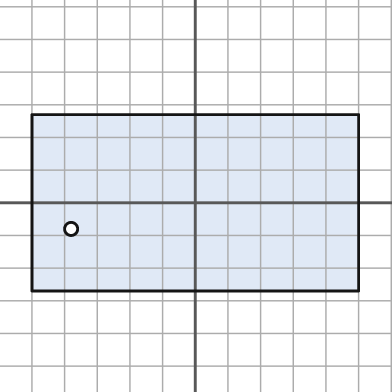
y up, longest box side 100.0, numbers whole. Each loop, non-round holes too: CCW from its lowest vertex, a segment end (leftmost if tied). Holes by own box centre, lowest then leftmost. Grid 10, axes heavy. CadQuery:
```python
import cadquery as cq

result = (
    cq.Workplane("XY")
    .moveTo(-50.0, -27.0)
    .lineTo(50.0, -27.0)
    .lineTo(50.0, 27.0)
    .lineTo(-50.0, 27.0)
    .close()
    .moveTo(-38.0, -8.0)
    .circle(2.0)
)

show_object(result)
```